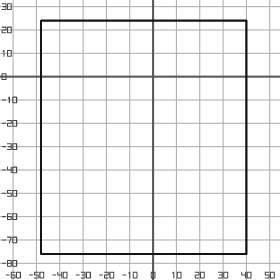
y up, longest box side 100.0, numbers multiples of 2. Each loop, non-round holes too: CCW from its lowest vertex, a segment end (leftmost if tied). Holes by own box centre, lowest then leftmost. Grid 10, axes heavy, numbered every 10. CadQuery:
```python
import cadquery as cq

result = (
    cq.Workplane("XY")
    .moveTo(-48.0, -76.0)
    .lineTo(40.0, -76.0)
    .lineTo(40.0, 24.0)
    .lineTo(-48.0, 24.0)
    .close()
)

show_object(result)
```